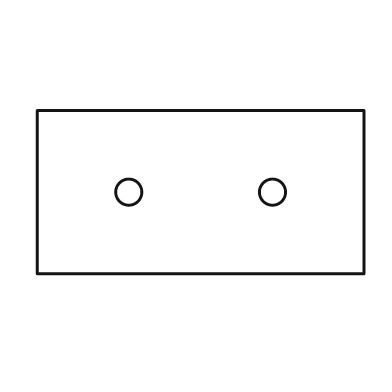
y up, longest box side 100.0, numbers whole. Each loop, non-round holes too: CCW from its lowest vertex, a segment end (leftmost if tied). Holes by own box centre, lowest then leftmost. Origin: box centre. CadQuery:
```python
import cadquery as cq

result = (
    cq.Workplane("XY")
    .moveTo(-50.0, -25.0)
    .lineTo(50.0, -25.0)
    .lineTo(50.0, 25.0)
    .lineTo(-50.0, 25.0)
    .close()
    .moveTo(-22.0, 0.0)
    .circle(4.0)
    .moveTo(22.0, 0.0)
    .circle(4.0)
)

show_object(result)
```